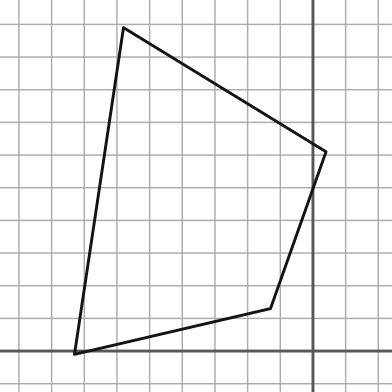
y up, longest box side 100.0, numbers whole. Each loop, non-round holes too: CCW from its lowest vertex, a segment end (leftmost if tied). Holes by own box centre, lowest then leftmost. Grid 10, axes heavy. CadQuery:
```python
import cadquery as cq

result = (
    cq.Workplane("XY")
    .moveTo(-73.0, -1.0)
    .lineTo(-13.0, 13.0)
    .lineTo(4.0, 61.0)
    .lineTo(-58.0, 99.0)
    .close()
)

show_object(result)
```